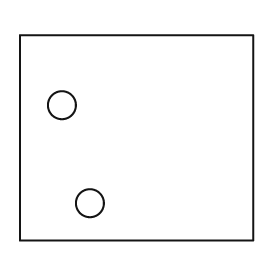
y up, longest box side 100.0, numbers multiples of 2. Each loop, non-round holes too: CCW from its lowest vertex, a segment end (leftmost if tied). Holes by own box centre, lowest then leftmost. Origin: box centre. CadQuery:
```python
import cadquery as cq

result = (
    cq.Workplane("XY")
    .moveTo(-50.0, -44.0)
    .lineTo(50.0, -44.0)
    .lineTo(50.0, 44.0)
    .lineTo(-50.0, 44.0)
    .close()
    .moveTo(-20.0, -28.0)
    .circle(6.0)
    .moveTo(-32.0, 14.0)
    .circle(6.0)
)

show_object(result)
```